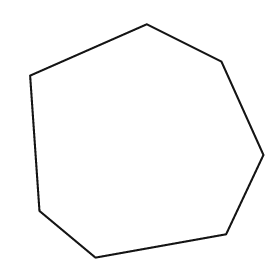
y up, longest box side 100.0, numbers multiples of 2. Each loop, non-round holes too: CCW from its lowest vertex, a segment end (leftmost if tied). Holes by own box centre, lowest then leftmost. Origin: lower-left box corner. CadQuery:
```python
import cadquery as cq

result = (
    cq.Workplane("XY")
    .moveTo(28.0, 0.0)
    .lineTo(84.0, 10.0)
    .lineTo(100.0, 44.0)
    .lineTo(82.0, 84.0)
    .lineTo(50.0, 100.0)
    .lineTo(0.0, 78.0)
    .lineTo(4.0, 20.0)
    .close()
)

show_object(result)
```